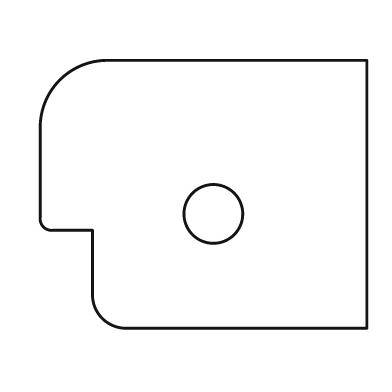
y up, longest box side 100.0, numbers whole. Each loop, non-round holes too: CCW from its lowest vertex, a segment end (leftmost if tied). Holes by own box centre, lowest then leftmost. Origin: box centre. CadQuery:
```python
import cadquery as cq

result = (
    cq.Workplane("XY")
    .moveTo(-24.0, -41.0)
    .lineTo(50.0, -41.0)
    .lineTo(50.0, 41.0)
    .lineTo(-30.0, 41.0)
    .threePointArc((-44.0, 35.0), (-50.0, 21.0))
    .lineTo(-50.0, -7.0)
    .threePointArc((-49.0, -10.0), (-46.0, -11.0))
    .lineTo(-34.0, -11.0)
    .lineTo(-34.0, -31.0)
    .threePointArc((-31.0, -38.0), (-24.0, -41.0))
    .close()
    .moveTo(3.0, -6.0)
    .circle(9.0)
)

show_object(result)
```